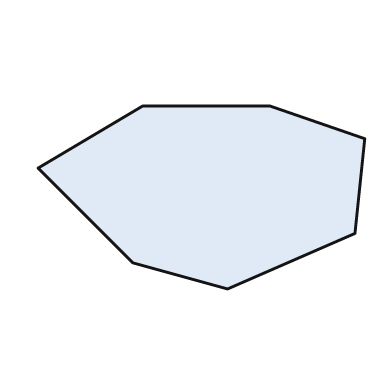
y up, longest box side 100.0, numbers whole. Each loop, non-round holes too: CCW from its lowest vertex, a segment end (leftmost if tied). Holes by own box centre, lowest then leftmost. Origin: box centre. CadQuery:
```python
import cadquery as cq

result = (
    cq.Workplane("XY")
    .moveTo(8.0, -28.0)
    .lineTo(47.0, -11.0)
    .lineTo(50.0, 18.0)
    .lineTo(21.0, 28.0)
    .lineTo(-18.0, 28.0)
    .lineTo(-50.0, 9.0)
    .lineTo(-21.0, -20.0)
    .close()
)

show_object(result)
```